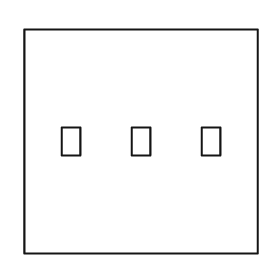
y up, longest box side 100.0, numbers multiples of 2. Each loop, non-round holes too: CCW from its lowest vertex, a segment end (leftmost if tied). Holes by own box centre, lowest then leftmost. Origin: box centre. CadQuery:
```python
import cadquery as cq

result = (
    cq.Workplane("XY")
    .moveTo(-50.0, -48.0)
    .lineTo(50.0, -48.0)
    .lineTo(50.0, 48.0)
    .lineTo(-50.0, 48.0)
    .close()
    .moveTo(-34.0, -6.0)
    .lineTo(-26.0, -6.0)
    .lineTo(-26.0, 6.0)
    .lineTo(-34.0, 6.0)
    .close()
    .moveTo(-4.0, -6.0)
    .lineTo(4.0, -6.0)
    .lineTo(4.0, 6.0)
    .lineTo(-4.0, 6.0)
    .close()
    .moveTo(26.0, -6.0)
    .lineTo(34.0, -6.0)
    .lineTo(34.0, 6.0)
    .lineTo(26.0, 6.0)
    .close()
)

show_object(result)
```